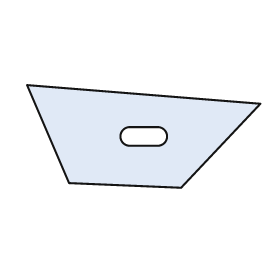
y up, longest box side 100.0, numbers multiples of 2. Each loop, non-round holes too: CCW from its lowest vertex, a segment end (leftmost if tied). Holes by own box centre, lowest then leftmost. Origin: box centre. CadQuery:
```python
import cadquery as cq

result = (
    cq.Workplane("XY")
    .moveTo(16.0, -22.0)
    .lineTo(50.0, 14.0)
    .lineTo(-50.0, 22.0)
    .lineTo(-32.0, -20.0)
    .close()
    .moveTo(-6.0, -4.0)
    .lineTo(6.0, -4.0)
    .threePointArc((10.0, 0.0), (6.0, 4.0))
    .lineTo(-6.0, 4.0)
    .threePointArc((-10.0, 0.0), (-6.0, -4.0))
    .close()
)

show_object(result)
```